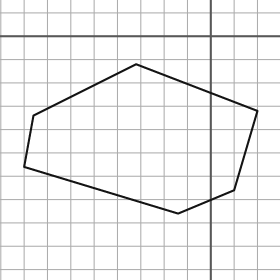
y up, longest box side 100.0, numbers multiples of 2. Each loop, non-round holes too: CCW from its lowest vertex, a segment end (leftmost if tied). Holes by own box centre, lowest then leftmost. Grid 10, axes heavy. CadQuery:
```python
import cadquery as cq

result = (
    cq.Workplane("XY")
    .moveTo(-14.0, -76.0)
    .lineTo(10.0, -66.0)
    .lineTo(20.0, -32.0)
    .lineTo(-32.0, -12.0)
    .lineTo(-76.0, -34.0)
    .lineTo(-80.0, -56.0)
    .close()
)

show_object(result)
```